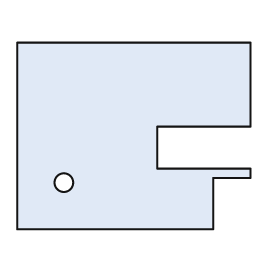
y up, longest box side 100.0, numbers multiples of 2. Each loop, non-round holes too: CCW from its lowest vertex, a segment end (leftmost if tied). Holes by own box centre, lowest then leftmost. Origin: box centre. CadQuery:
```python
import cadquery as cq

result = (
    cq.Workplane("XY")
    .moveTo(-50.0, -40.0)
    .lineTo(34.0, -40.0)
    .lineTo(34.0, -18.0)
    .lineTo(50.0, -18.0)
    .lineTo(50.0, -14.0)
    .lineTo(10.0, -14.0)
    .lineTo(10.0, 4.0)
    .lineTo(50.0, 4.0)
    .lineTo(50.0, 40.0)
    .lineTo(-50.0, 40.0)
    .close()
    .moveTo(-30.0, -20.0)
    .circle(4.0)
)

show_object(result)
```